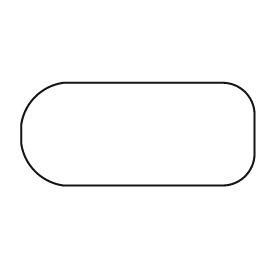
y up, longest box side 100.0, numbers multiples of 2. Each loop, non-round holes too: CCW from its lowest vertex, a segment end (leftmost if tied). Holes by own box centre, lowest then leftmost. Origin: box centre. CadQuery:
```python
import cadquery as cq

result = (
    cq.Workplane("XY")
    .moveTo(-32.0, -22.0)
    .lineTo(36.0, -22.0)
    .threePointArc((46.0, -18.0), (50.0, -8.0))
    .lineTo(50.0, 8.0)
    .threePointArc((46.0, 18.0), (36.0, 22.0))
    .lineTo(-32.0, 22.0)
    .threePointArc((-44.0, 16.0), (-50.0, 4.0))
    .lineTo(-50.0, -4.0)
    .threePointArc((-44.0, -16.0), (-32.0, -22.0))
    .close()
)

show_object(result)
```